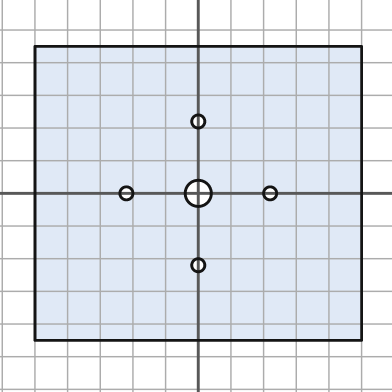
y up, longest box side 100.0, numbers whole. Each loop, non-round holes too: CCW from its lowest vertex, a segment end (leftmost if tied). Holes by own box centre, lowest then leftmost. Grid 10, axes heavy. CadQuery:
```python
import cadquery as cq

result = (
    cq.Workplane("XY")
    .moveTo(-50.0, -45.0)
    .lineTo(50.0, -45.0)
    .lineTo(50.0, 45.0)
    .lineTo(-50.0, 45.0)
    .close()
    .moveTo(0.0, -22.0)
    .circle(2.0)
    .moveTo(-22.0, 0.0)
    .circle(2.0)
    .moveTo(0.0, 0.0)
    .circle(4.0)
    .moveTo(22.0, 0.0)
    .circle(2.0)
    .moveTo(0.0, 22.0)
    .circle(2.0)
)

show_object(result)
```